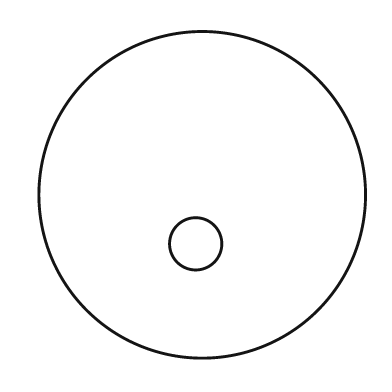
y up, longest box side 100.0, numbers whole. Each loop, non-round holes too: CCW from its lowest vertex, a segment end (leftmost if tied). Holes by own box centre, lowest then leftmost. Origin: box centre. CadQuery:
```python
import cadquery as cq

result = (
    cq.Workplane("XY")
    .moveTo(0.0, 0.0)
    .circle(50.0)
    .moveTo(-2.0, -15.0)
    .circle(8.0)
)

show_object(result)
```